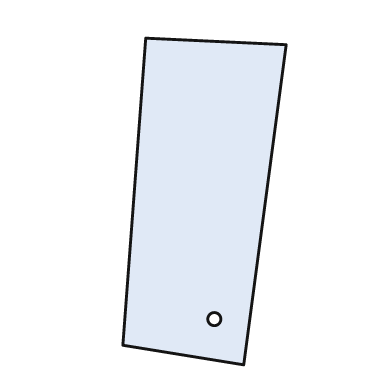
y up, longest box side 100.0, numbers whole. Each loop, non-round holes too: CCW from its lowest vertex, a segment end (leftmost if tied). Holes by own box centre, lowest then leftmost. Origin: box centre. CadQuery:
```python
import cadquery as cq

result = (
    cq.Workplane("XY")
    .moveTo(12.0, -50.0)
    .lineTo(25.0, 48.0)
    .lineTo(-18.0, 50.0)
    .lineTo(-25.0, -44.0)
    .close()
    .moveTo(3.0, -36.0)
    .circle(2.0)
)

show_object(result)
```